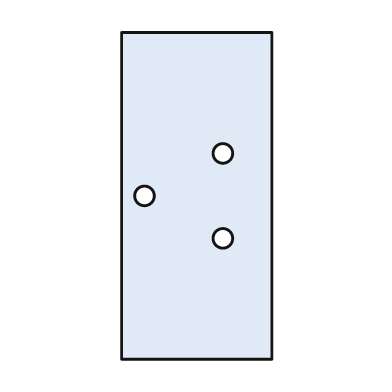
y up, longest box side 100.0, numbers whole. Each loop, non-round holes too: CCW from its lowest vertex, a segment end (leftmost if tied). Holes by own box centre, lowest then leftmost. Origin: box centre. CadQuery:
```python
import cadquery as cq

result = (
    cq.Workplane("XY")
    .moveTo(-23.0, -50.0)
    .lineTo(23.0, -50.0)
    .lineTo(23.0, 50.0)
    .lineTo(-23.0, 50.0)
    .close()
    .moveTo(8.0, -13.0)
    .circle(3.0)
    .moveTo(-16.0, 0.0)
    .circle(3.0)
    .moveTo(8.0, 13.0)
    .circle(3.0)
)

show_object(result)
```